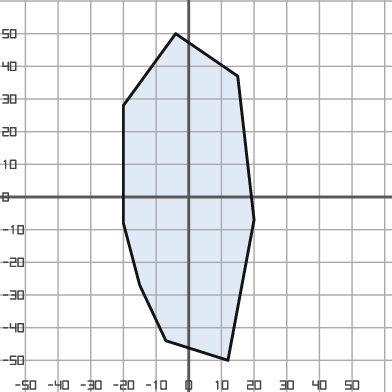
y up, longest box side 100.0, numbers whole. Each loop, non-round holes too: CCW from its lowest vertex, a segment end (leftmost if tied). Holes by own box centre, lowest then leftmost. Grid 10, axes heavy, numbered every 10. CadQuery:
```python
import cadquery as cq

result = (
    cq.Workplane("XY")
    .moveTo(12.0, -50.0)
    .lineTo(20.0, -7.0)
    .lineTo(15.0, 37.0)
    .lineTo(-4.0, 50.0)
    .lineTo(-20.0, 28.0)
    .lineTo(-20.0, -8.0)
    .lineTo(-15.0, -27.0)
    .lineTo(-7.0, -44.0)
    .close()
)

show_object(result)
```